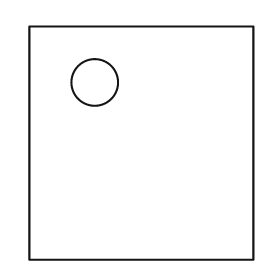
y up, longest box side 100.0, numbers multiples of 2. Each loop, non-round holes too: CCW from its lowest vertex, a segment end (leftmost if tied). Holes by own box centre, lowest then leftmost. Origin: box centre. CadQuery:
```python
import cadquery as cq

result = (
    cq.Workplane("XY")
    .moveTo(-48.0, -50.0)
    .lineTo(48.0, -50.0)
    .lineTo(48.0, 50.0)
    .lineTo(-48.0, 50.0)
    .close()
    .moveTo(-20.0, 26.0)
    .circle(10.0)
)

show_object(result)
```